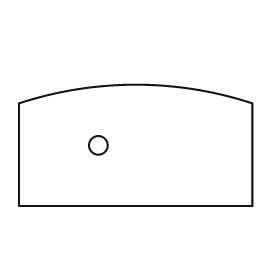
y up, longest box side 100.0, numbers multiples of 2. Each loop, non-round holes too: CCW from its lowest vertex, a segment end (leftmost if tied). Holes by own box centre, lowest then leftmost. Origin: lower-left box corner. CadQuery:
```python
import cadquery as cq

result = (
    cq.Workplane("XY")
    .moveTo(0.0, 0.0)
    .lineTo(100.0, 0.0)
    .lineTo(100.0, 44.0)
    .threePointArc((50.0, 52.0), (0.0, 44.0))
    .close()
    .moveTo(34.0, 26.0)
    .circle(4.0)
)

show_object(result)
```